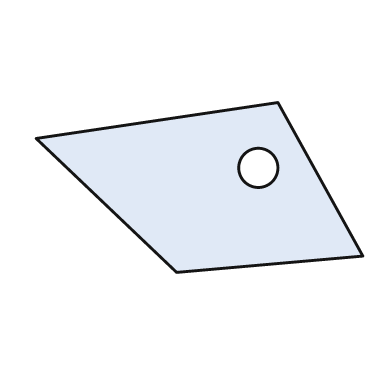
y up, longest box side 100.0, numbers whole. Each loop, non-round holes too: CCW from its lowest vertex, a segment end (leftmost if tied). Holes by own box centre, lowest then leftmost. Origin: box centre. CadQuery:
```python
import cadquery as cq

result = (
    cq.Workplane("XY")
    .moveTo(-7.0, -26.0)
    .lineTo(50.0, -21.0)
    .lineTo(24.0, 26.0)
    .lineTo(-50.0, 15.0)
    .close()
    .moveTo(18.0, 6.0)
    .circle(6.0)
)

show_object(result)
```